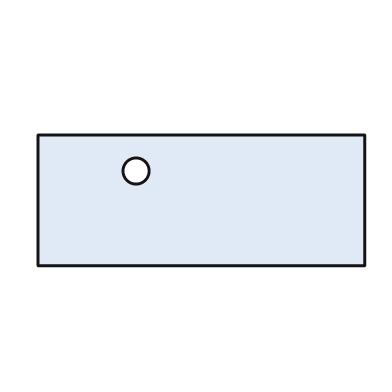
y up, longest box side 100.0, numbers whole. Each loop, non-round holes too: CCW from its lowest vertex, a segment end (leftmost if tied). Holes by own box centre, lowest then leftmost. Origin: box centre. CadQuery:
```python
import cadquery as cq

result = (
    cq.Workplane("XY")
    .moveTo(-50.0, -20.0)
    .lineTo(50.0, -20.0)
    .lineTo(50.0, 20.0)
    .lineTo(-50.0, 20.0)
    .close()
    .moveTo(-20.0, 9.0)
    .circle(4.0)
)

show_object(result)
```